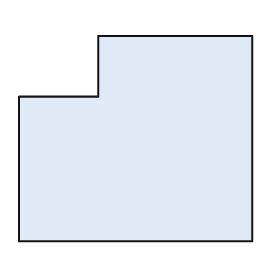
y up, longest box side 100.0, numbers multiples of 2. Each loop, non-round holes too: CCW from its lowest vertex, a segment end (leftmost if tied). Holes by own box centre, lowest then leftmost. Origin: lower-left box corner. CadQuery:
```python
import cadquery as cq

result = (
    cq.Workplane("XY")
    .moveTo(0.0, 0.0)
    .lineTo(100.0, 0.0)
    .lineTo(100.0, 88.0)
    .lineTo(34.0, 88.0)
    .lineTo(34.0, 62.0)
    .lineTo(0.0, 62.0)
    .close()
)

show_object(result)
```